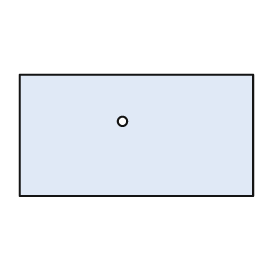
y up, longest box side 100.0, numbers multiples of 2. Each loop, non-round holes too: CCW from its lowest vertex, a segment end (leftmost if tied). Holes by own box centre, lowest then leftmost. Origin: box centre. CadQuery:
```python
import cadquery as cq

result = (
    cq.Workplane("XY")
    .moveTo(-50.0, -26.0)
    .lineTo(50.0, -26.0)
    .lineTo(50.0, 26.0)
    .lineTo(-50.0, 26.0)
    .close()
    .moveTo(-6.0, 6.0)
    .circle(2.0)
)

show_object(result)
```